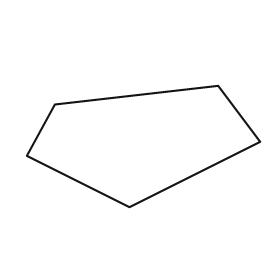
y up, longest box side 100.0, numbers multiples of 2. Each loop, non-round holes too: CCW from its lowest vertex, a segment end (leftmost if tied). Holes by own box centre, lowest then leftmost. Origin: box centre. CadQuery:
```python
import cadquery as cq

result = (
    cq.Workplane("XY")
    .moveTo(-6.0, -26.0)
    .lineTo(50.0, 2.0)
    .lineTo(32.0, 26.0)
    .lineTo(-38.0, 18.0)
    .lineTo(-50.0, -4.0)
    .close()
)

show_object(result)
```